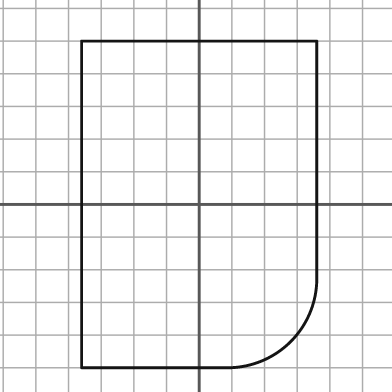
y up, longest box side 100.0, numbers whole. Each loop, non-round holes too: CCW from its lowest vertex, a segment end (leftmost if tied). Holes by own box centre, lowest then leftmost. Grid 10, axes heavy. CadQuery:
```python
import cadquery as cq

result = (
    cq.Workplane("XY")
    .moveTo(-36.0, -50.0)
    .lineTo(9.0, -50.0)
    .threePointArc((28.0, -42.0), (36.0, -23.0))
    .lineTo(36.0, 50.0)
    .lineTo(-36.0, 50.0)
    .close()
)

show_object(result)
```